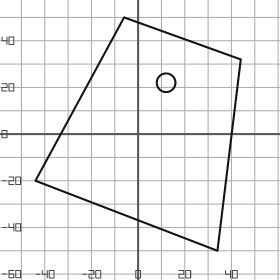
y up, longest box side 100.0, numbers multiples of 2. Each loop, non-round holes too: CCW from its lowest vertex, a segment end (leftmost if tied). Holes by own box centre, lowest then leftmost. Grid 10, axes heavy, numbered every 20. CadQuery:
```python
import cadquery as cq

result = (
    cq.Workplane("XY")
    .moveTo(34.0, -50.0)
    .lineTo(44.0, 32.0)
    .lineTo(-6.0, 50.0)
    .lineTo(-44.0, -20.0)
    .close()
    .moveTo(12.0, 22.0)
    .circle(4.0)
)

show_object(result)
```